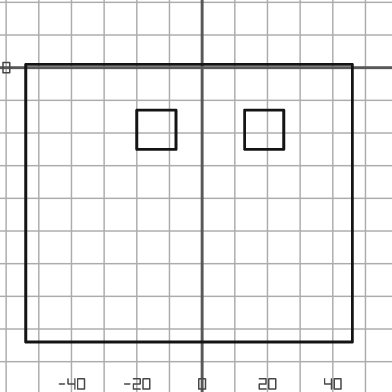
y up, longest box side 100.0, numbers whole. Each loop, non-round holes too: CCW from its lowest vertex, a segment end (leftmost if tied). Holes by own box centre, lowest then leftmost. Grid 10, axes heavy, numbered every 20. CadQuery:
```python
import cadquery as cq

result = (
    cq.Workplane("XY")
    .moveTo(-54.0, -84.0)
    .lineTo(46.0, -84.0)
    .lineTo(46.0, 1.0)
    .lineTo(-54.0, 1.0)
    .close()
    .moveTo(-20.0, -25.0)
    .lineTo(-8.0, -25.0)
    .lineTo(-8.0, -13.0)
    .lineTo(-20.0, -13.0)
    .close()
    .moveTo(13.0, -25.0)
    .lineTo(25.0, -25.0)
    .lineTo(25.0, -13.0)
    .lineTo(13.0, -13.0)
    .close()
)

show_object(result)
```